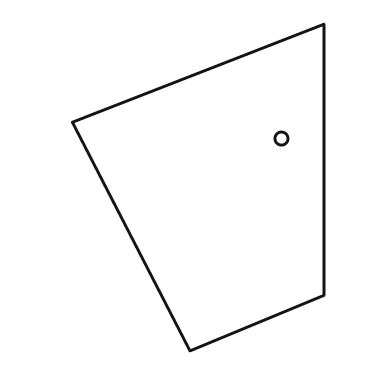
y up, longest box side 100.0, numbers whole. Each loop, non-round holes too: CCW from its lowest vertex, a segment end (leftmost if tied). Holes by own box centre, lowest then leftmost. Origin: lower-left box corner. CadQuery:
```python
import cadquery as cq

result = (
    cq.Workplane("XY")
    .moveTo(36.0, 0.0)
    .lineTo(77.0, 17.0)
    .lineTo(77.0, 100.0)
    .lineTo(0.0, 70.0)
    .close()
    .moveTo(64.0, 65.0)
    .circle(2.0)
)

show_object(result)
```